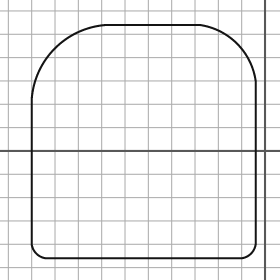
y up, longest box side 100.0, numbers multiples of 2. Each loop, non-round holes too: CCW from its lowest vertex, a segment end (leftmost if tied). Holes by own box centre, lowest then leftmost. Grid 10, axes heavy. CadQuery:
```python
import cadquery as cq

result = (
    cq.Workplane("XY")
    .moveTo(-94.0, -46.0)
    .lineTo(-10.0, -46.0)
    .threePointArc((-6.0, -44.0), (-4.0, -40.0))
    .lineTo(-4.0, 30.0)
    .threePointArc((-12.0, 46.0), (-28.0, 54.0))
    .lineTo(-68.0, 54.0)
    .threePointArc((-90.0, 44.0), (-100.0, 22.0))
    .lineTo(-100.0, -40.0)
    .threePointArc((-98.0, -44.0), (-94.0, -46.0))
    .close()
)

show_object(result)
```